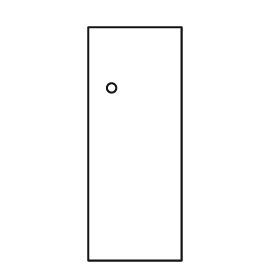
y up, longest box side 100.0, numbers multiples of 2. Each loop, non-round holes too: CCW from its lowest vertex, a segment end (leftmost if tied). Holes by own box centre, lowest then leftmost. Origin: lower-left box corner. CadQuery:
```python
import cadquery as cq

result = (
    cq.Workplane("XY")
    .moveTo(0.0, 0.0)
    .lineTo(40.0, 0.0)
    .lineTo(40.0, 100.0)
    .lineTo(0.0, 100.0)
    .close()
    .moveTo(10.0, 74.0)
    .circle(2.0)
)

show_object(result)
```